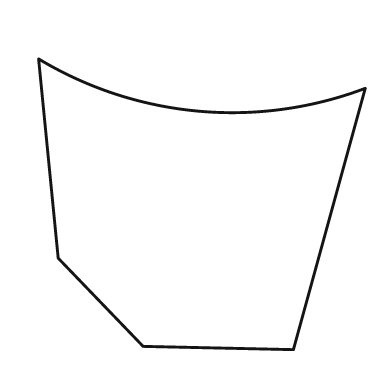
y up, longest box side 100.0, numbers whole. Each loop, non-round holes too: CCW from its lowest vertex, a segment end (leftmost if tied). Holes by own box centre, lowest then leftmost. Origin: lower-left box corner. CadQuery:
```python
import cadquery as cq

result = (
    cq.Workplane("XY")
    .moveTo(78.0, 0.0)
    .lineTo(100.0, 80.0)
    .threePointArc((49.0, 73.0), (0.0, 89.0))
    .lineTo(6.0, 28.0)
    .lineTo(32.0, 1.0)
    .close()
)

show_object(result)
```